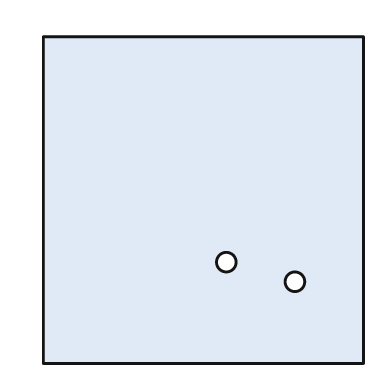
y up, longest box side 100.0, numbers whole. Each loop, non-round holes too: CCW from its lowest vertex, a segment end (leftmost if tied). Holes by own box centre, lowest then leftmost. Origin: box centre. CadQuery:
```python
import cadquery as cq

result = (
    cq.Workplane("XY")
    .moveTo(-49.0, -50.0)
    .lineTo(49.0, -50.0)
    .lineTo(49.0, 50.0)
    .lineTo(-49.0, 50.0)
    .close()
    .moveTo(28.0, -25.0)
    .circle(3.0)
    .moveTo(7.0, -19.0)
    .circle(3.0)
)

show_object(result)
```